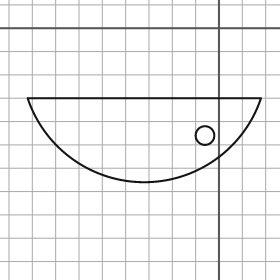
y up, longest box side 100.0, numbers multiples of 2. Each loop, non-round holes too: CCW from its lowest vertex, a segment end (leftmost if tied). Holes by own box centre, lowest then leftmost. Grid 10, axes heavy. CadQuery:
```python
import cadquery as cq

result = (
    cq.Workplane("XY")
    .moveTo(-82.0, -30.0)
    .threePointArc((-32.0, -66.0), (18.0, -30.0))
    .close()
    .moveTo(-6.0, -46.0)
    .circle(4.0)
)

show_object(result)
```